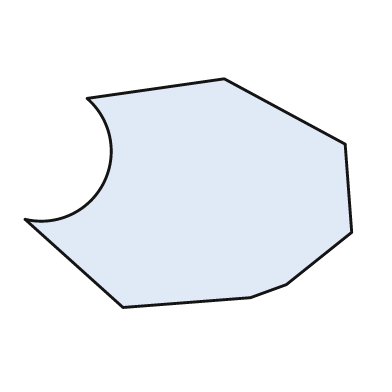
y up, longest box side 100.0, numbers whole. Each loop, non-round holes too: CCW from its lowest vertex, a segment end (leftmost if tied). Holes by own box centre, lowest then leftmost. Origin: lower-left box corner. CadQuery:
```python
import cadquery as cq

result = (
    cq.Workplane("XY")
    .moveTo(30.0, 0.0)
    .lineTo(69.0, 3.0)
    .lineTo(80.0, 7.0)
    .lineTo(100.0, 23.0)
    .lineTo(98.0, 50.0)
    .lineTo(61.0, 70.0)
    .lineTo(19.0, 64.0)
    .threePointArc((24.0, 38.0), (0.0, 27.0))
    .close()
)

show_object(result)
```